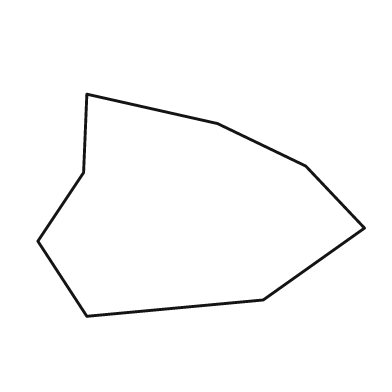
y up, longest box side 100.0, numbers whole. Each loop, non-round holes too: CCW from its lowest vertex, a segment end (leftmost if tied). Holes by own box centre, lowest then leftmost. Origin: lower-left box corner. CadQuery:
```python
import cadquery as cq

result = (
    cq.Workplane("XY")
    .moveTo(15.0, 0.0)
    .lineTo(69.0, 5.0)
    .lineTo(100.0, 27.0)
    .lineTo(82.0, 46.0)
    .lineTo(55.0, 59.0)
    .lineTo(15.0, 68.0)
    .lineTo(14.0, 44.0)
    .lineTo(0.0, 23.0)
    .close()
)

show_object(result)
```